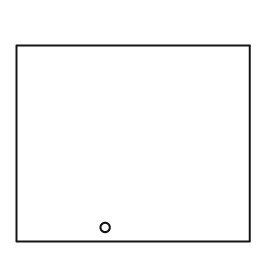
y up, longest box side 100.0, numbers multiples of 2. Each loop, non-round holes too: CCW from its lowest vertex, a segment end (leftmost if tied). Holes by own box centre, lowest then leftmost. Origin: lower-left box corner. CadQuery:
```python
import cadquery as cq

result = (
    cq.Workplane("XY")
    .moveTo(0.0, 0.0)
    .lineTo(100.0, 0.0)
    .lineTo(100.0, 84.0)
    .lineTo(0.0, 84.0)
    .close()
    .moveTo(38.0, 6.0)
    .circle(2.0)
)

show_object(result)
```